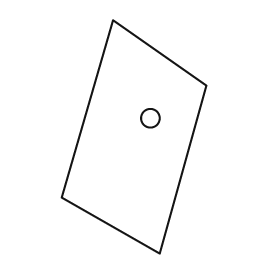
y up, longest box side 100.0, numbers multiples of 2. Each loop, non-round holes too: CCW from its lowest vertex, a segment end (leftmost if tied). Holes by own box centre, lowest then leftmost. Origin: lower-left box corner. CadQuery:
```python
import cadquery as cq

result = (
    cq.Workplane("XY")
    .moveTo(42.0, 0.0)
    .lineTo(62.0, 72.0)
    .lineTo(22.0, 100.0)
    .lineTo(0.0, 24.0)
    .close()
    .moveTo(38.0, 58.0)
    .circle(4.0)
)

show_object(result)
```